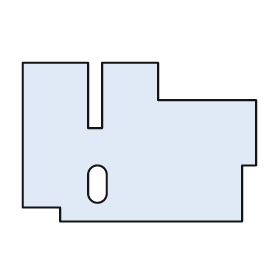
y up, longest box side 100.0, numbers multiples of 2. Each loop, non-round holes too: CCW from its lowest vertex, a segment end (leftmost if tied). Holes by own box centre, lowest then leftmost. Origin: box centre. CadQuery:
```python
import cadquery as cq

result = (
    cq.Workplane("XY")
    .moveTo(-34.0, -34.0)
    .lineTo(44.0, -34.0)
    .lineTo(44.0, -10.0)
    .lineTo(50.0, -10.0)
    .lineTo(50.0, 18.0)
    .lineTo(8.0, 18.0)
    .lineTo(8.0, 34.0)
    .lineTo(-16.0, 34.0)
    .lineTo(-16.0, 6.0)
    .lineTo(-22.0, 6.0)
    .lineTo(-22.0, 34.0)
    .lineTo(-50.0, 34.0)
    .lineTo(-50.0, -28.0)
    .lineTo(-34.0, -28.0)
    .close()
    .moveTo(-22.0, -22.0)
    .threePointArc((-18.0, -26.0), (-14.0, -22.0))
    .lineTo(-14.0, -14.0)
    .threePointArc((-18.0, -10.0), (-22.0, -14.0))
    .close()
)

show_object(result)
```